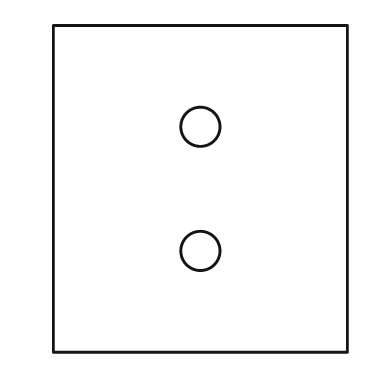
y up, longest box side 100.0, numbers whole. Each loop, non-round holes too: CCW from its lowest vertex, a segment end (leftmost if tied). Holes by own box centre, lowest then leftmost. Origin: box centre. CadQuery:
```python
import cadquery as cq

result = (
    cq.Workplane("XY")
    .moveTo(-45.0, -50.0)
    .lineTo(45.0, -50.0)
    .lineTo(45.0, 50.0)
    .lineTo(-45.0, 50.0)
    .close()
    .moveTo(0.0, -19.0)
    .circle(6.0)
    .moveTo(0.0, 19.0)
    .circle(6.0)
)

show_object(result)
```